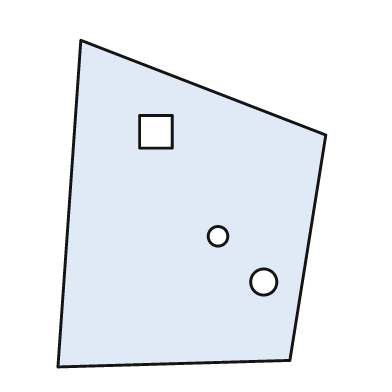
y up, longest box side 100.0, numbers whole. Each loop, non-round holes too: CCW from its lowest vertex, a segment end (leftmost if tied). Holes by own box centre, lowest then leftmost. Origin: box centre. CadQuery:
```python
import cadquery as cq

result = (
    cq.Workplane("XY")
    .moveTo(-41.0, -50.0)
    .lineTo(30.0, -48.0)
    .lineTo(41.0, 21.0)
    .lineTo(-34.0, 50.0)
    .close()
    .moveTo(22.0, -24.0)
    .circle(4.0)
    .moveTo(8.0, -10.0)
    .circle(3.0)
    .moveTo(-16.0, 17.0)
    .lineTo(-6.0, 17.0)
    .lineTo(-6.0, 27.0)
    .lineTo(-16.0, 27.0)
    .close()
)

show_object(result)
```